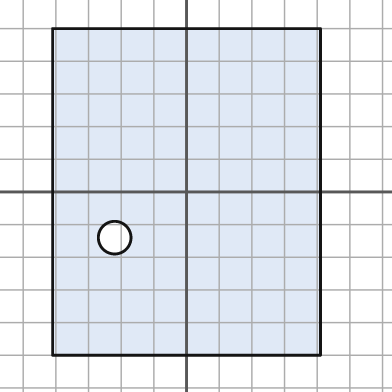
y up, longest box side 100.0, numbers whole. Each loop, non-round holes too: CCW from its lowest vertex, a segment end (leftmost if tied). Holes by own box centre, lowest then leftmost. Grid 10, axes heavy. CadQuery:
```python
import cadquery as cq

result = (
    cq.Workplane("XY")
    .moveTo(-41.0, -50.0)
    .lineTo(41.0, -50.0)
    .lineTo(41.0, 50.0)
    .lineTo(-41.0, 50.0)
    .close()
    .moveTo(-22.0, -14.0)
    .circle(5.0)
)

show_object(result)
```